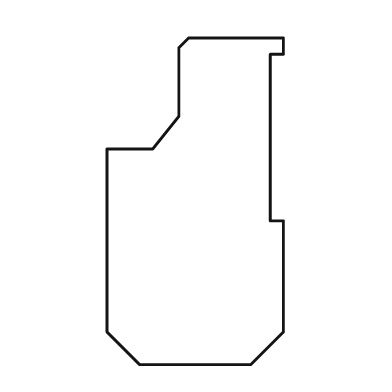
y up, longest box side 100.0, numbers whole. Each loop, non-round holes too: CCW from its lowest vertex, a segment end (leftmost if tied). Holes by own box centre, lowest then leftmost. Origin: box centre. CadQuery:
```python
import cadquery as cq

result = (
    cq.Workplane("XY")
    .moveTo(-17.0, -50.0)
    .lineTo(17.0, -50.0)
    .lineTo(27.0, -40.0)
    .lineTo(27.0, -6.0)
    .lineTo(23.0, -6.0)
    .lineTo(23.0, 45.0)
    .lineTo(27.0, 45.0)
    .lineTo(27.0, 50.0)
    .lineTo(-2.0, 50.0)
    .lineTo(-5.0, 47.0)
    .lineTo(-5.0, 26.0)
    .lineTo(-13.0, 16.0)
    .lineTo(-27.0, 16.0)
    .lineTo(-27.0, -40.0)
    .close()
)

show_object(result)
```